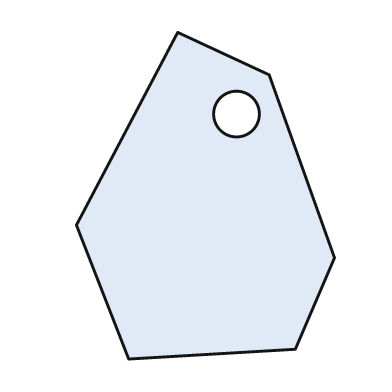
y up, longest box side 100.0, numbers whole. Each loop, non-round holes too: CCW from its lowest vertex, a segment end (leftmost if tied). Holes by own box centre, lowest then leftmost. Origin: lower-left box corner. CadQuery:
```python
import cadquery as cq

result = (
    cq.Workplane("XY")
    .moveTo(16.0, 0.0)
    .lineTo(67.0, 3.0)
    .lineTo(79.0, 31.0)
    .lineTo(59.0, 87.0)
    .lineTo(31.0, 100.0)
    .lineTo(0.0, 41.0)
    .close()
    .moveTo(49.0, 75.0)
    .circle(7.0)
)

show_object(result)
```